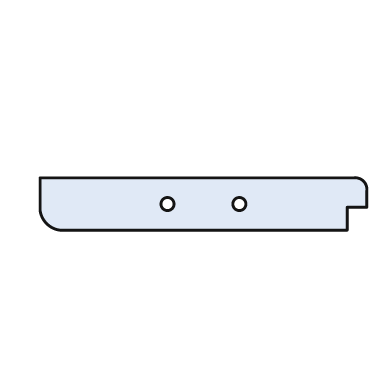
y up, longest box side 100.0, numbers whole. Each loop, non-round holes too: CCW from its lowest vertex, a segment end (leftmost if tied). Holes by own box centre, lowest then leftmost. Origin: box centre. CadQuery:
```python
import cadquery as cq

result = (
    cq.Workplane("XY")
    .moveTo(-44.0, -8.0)
    .lineTo(44.0, -8.0)
    .lineTo(44.0, -1.0)
    .lineTo(50.0, -1.0)
    .lineTo(50.0, 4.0)
    .threePointArc((49.0, 7.0), (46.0, 8.0))
    .lineTo(-50.0, 8.0)
    .lineTo(-50.0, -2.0)
    .threePointArc((-48.0, -6.0), (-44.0, -8.0))
    .close()
    .moveTo(-11.0, 0.0)
    .circle(2.0)
    .moveTo(11.0, 0.0)
    .circle(2.0)
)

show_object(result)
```